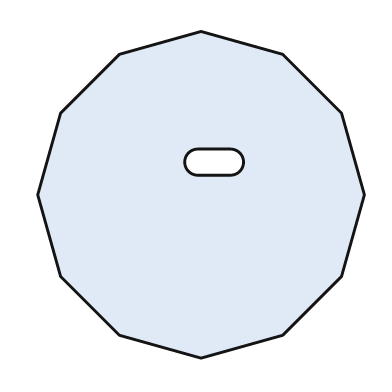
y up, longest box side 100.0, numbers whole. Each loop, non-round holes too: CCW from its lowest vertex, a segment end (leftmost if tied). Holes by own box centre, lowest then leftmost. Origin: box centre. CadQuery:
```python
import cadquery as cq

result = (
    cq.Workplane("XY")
    .moveTo(0.0, -50.0)
    .lineTo(25.0, -43.0)
    .lineTo(43.0, -25.0)
    .lineTo(50.0, 0.0)
    .lineTo(43.0, 25.0)
    .lineTo(25.0, 43.0)
    .lineTo(0.0, 50.0)
    .lineTo(-25.0, 43.0)
    .lineTo(-43.0, 25.0)
    .lineTo(-50.0, 0.0)
    .lineTo(-43.0, -25.0)
    .lineTo(-25.0, -43.0)
    .close()
    .moveTo(-1.0, 6.0)
    .lineTo(9.0, 6.0)
    .threePointArc((13.0, 10.0), (9.0, 14.0))
    .lineTo(-1.0, 14.0)
    .threePointArc((-5.0, 10.0), (-1.0, 6.0))
    .close()
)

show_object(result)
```